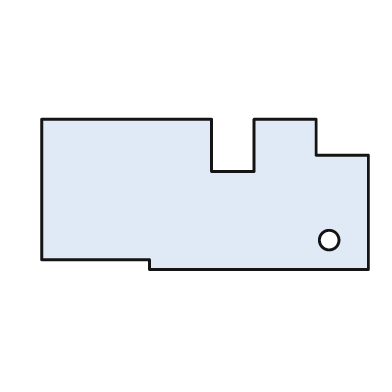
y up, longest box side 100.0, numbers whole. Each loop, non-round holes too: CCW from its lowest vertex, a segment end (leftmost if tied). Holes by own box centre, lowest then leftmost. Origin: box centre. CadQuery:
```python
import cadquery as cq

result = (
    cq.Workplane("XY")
    .moveTo(-17.0, -23.0)
    .lineTo(50.0, -23.0)
    .lineTo(50.0, 12.0)
    .lineTo(34.0, 12.0)
    .lineTo(34.0, 23.0)
    .lineTo(15.0, 23.0)
    .lineTo(15.0, 7.0)
    .lineTo(2.0, 7.0)
    .lineTo(2.0, 23.0)
    .lineTo(-50.0, 23.0)
    .lineTo(-50.0, -20.0)
    .lineTo(-17.0, -20.0)
    .close()
    .moveTo(38.0, -14.0)
    .circle(3.0)
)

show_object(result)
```